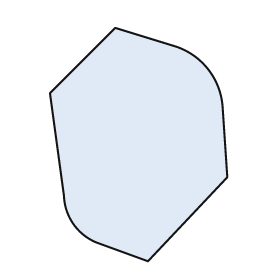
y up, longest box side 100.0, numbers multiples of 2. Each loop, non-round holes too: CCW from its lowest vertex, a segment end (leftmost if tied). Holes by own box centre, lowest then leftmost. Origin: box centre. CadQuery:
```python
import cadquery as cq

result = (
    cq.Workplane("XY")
    .moveTo(4.0, -50.0)
    .lineTo(38.0, -14.0)
    .lineTo(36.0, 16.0)
    .threePointArc((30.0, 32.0), (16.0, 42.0))
    .lineTo(-10.0, 50.0)
    .lineTo(-38.0, 22.0)
    .lineTo(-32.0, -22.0)
    .threePointArc((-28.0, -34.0), (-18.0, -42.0))
    .close()
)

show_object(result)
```